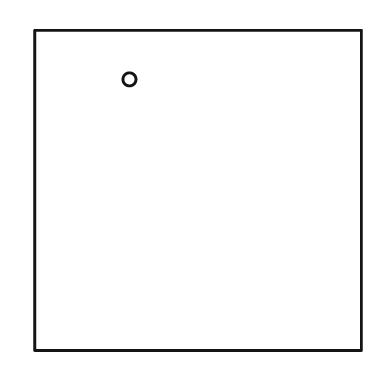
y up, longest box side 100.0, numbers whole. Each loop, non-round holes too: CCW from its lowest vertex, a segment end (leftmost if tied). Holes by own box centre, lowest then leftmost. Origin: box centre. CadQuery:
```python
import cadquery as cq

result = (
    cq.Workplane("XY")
    .moveTo(-50.0, -49.0)
    .lineTo(50.0, -49.0)
    .lineTo(50.0, 49.0)
    .lineTo(-50.0, 49.0)
    .close()
    .moveTo(-21.0, 34.0)
    .circle(2.0)
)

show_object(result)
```